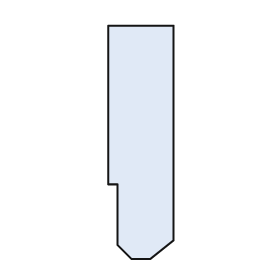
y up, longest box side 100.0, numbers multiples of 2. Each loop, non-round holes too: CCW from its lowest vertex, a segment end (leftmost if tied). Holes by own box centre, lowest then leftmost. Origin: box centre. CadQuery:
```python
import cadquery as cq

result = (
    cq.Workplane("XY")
    .moveTo(-4.0, -50.0)
    .lineTo(4.0, -50.0)
    .lineTo(14.0, -42.0)
    .lineTo(14.0, 50.0)
    .lineTo(-14.0, 50.0)
    .lineTo(-14.0, -18.0)
    .lineTo(-10.0, -18.0)
    .lineTo(-10.0, -44.0)
    .close()
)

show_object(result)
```